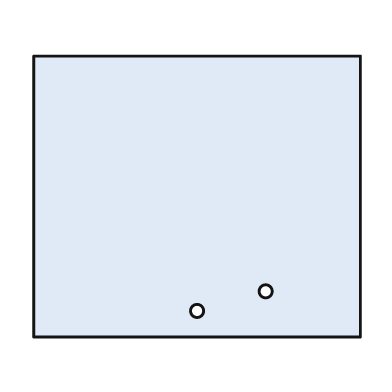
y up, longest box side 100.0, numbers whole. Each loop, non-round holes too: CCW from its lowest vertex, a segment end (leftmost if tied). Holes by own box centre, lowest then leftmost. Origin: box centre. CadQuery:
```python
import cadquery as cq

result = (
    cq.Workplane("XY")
    .moveTo(-50.0, -43.0)
    .lineTo(50.0, -43.0)
    .lineTo(50.0, 43.0)
    .lineTo(-50.0, 43.0)
    .close()
    .moveTo(0.0, -35.0)
    .circle(2.0)
    .moveTo(21.0, -29.0)
    .circle(2.0)
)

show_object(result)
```